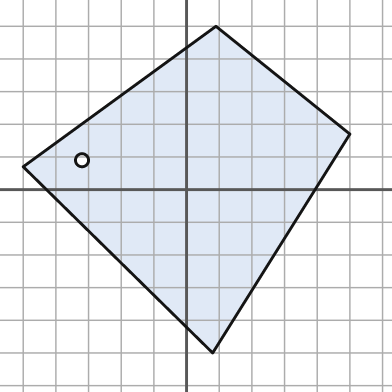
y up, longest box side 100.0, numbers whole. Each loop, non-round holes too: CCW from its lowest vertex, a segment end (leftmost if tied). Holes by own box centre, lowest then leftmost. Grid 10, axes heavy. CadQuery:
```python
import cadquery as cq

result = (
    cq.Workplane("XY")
    .moveTo(8.0, -50.0)
    .lineTo(50.0, 17.0)
    .lineTo(9.0, 50.0)
    .lineTo(-50.0, 7.0)
    .close()
    .moveTo(-32.0, 9.0)
    .circle(2.0)
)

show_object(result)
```